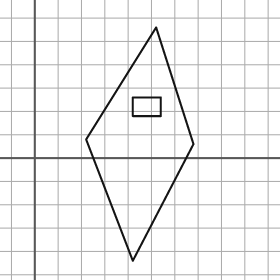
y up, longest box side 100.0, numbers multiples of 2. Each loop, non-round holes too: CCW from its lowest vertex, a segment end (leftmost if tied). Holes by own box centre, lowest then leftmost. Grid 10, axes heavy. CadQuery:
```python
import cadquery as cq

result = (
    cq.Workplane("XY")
    .moveTo(42.0, -44.0)
    .lineTo(68.0, 6.0)
    .lineTo(52.0, 56.0)
    .lineTo(22.0, 8.0)
    .close()
    .moveTo(42.0, 18.0)
    .lineTo(54.0, 18.0)
    .lineTo(54.0, 26.0)
    .lineTo(42.0, 26.0)
    .close()
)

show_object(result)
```